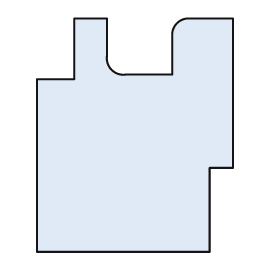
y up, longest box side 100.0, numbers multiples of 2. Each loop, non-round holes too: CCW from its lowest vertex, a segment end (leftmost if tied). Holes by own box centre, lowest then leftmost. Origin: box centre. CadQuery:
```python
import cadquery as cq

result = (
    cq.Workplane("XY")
    .moveTo(-42.0, -50.0)
    .lineTo(32.0, -50.0)
    .lineTo(32.0, -14.0)
    .lineTo(42.0, -14.0)
    .lineTo(42.0, 50.0)
    .lineTo(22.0, 50.0)
    .threePointArc((18.0, 48.0), (16.0, 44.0))
    .lineTo(16.0, 26.0)
    .lineTo(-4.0, 26.0)
    .threePointArc((-10.0, 28.0), (-12.0, 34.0))
    .lineTo(-12.0, 50.0)
    .lineTo(-26.0, 50.0)
    .lineTo(-26.0, 24.0)
    .lineTo(-42.0, 24.0)
    .close()
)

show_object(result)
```